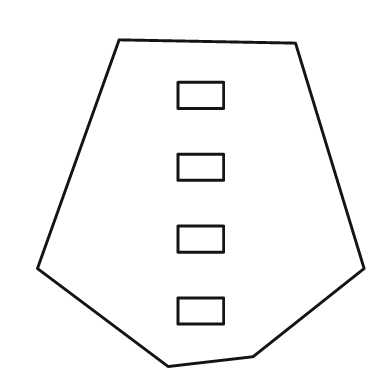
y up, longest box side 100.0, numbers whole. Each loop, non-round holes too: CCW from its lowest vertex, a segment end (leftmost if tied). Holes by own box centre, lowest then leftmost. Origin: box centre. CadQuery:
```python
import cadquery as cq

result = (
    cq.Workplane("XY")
    .moveTo(-10.0, -50.0)
    .lineTo(16.0, -47.0)
    .lineTo(50.0, -20.0)
    .lineTo(29.0, 49.0)
    .lineTo(-25.0, 50.0)
    .lineTo(-50.0, -20.0)
    .close()
    .moveTo(-7.0, -37.0)
    .lineTo(7.0, -37.0)
    .lineTo(7.0, -29.0)
    .lineTo(-7.0, -29.0)
    .close()
    .moveTo(-7.0, -15.0)
    .lineTo(7.0, -15.0)
    .lineTo(7.0, -7.0)
    .lineTo(-7.0, -7.0)
    .close()
    .moveTo(-7.0, 7.0)
    .lineTo(7.0, 7.0)
    .lineTo(7.0, 15.0)
    .lineTo(-7.0, 15.0)
    .close()
    .moveTo(-7.0, 29.0)
    .lineTo(7.0, 29.0)
    .lineTo(7.0, 37.0)
    .lineTo(-7.0, 37.0)
    .close()
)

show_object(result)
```